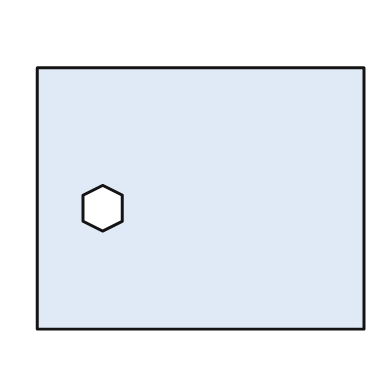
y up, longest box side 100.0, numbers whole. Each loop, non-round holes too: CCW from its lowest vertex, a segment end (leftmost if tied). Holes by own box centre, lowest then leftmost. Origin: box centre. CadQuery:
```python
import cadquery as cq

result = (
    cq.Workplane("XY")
    .moveTo(-50.0, -40.0)
    .lineTo(50.0, -40.0)
    .lineTo(50.0, 40.0)
    .lineTo(-50.0, 40.0)
    .close()
    .moveTo(-30.0, -10.0)
    .lineTo(-24.0, -7.0)
    .lineTo(-24.0, 1.0)
    .lineTo(-30.0, 4.0)
    .lineTo(-36.0, 1.0)
    .lineTo(-36.0, -7.0)
    .close()
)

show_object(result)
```